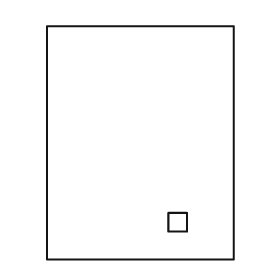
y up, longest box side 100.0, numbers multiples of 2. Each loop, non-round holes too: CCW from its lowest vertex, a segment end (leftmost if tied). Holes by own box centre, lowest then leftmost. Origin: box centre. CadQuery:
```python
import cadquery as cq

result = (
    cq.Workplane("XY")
    .moveTo(-40.0, -50.0)
    .lineTo(40.0, -50.0)
    .lineTo(40.0, 50.0)
    .lineTo(-40.0, 50.0)
    .close()
    .moveTo(12.0, -38.0)
    .lineTo(20.0, -38.0)
    .lineTo(20.0, -30.0)
    .lineTo(12.0, -30.0)
    .close()
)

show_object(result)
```